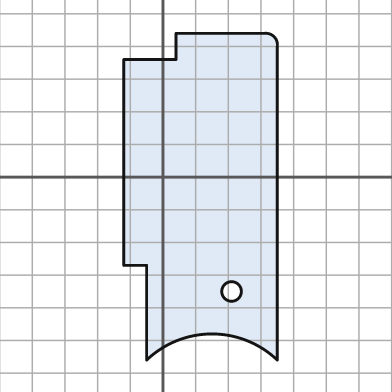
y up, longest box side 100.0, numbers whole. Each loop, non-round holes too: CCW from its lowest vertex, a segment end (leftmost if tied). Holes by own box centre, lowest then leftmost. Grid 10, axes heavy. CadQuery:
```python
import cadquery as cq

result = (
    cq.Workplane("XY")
    .moveTo(-5.0, -56.0)
    .threePointArc((15.0, -48.0), (35.0, -56.0))
    .lineTo(35.0, 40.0)
    .threePointArc((34.0, 43.0), (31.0, 44.0))
    .lineTo(4.0, 44.0)
    .lineTo(4.0, 36.0)
    .lineTo(-12.0, 36.0)
    .lineTo(-12.0, -27.0)
    .lineTo(-5.0, -27.0)
    .close()
    .moveTo(21.0, -35.0)
    .circle(3.0)
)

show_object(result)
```